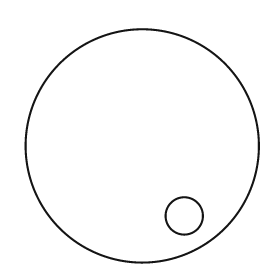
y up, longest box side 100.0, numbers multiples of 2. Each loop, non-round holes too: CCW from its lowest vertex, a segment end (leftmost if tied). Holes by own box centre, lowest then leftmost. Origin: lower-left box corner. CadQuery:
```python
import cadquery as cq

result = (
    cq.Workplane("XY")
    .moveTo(50.0, 50.0)
    .circle(50.0)
    .moveTo(68.0, 20.0)
    .circle(8.0)
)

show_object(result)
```